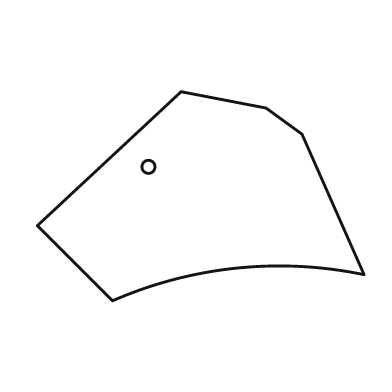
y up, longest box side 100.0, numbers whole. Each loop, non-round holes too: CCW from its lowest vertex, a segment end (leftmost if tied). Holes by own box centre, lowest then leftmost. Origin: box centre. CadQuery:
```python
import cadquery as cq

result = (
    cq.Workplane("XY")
    .moveTo(-27.0, -32.0)
    .threePointArc((11.0, -22.0), (50.0, -24.0))
    .lineTo(31.0, 19.0)
    .lineTo(20.0, 27.0)
    .lineTo(-6.0, 32.0)
    .lineTo(-50.0, -9.0)
    .close()
    .moveTo(-16.0, 9.0)
    .circle(2.0)
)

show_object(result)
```